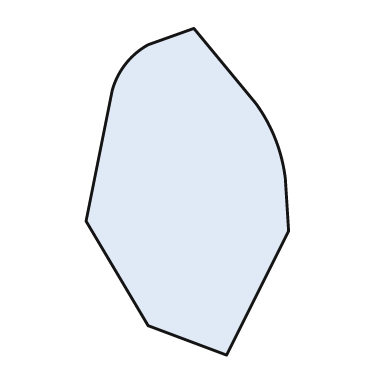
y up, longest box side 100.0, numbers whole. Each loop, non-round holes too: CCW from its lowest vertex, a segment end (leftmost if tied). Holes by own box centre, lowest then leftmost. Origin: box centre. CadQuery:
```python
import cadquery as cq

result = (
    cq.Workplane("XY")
    .moveTo(12.0, -50.0)
    .lineTo(31.0, -12.0)
    .lineTo(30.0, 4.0)
    .threePointArc((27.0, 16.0), (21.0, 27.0))
    .lineTo(2.0, 50.0)
    .lineTo(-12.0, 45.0)
    .threePointArc((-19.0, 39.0), (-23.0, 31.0))
    .lineTo(-31.0, -9.0)
    .lineTo(-12.0, -41.0)
    .close()
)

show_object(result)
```